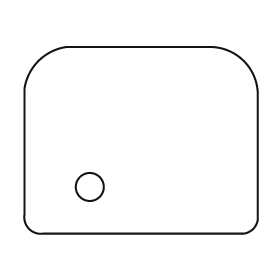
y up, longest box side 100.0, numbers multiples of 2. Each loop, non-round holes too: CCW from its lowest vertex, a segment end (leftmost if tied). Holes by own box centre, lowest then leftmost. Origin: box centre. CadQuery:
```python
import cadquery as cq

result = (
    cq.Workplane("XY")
    .moveTo(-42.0, -40.0)
    .lineTo(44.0, -40.0)
    .threePointArc((48.0, -38.0), (50.0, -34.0))
    .lineTo(50.0, 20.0)
    .threePointArc((44.0, 34.0), (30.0, 40.0))
    .lineTo(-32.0, 40.0)
    .threePointArc((-44.0, 34.0), (-50.0, 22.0))
    .lineTo(-50.0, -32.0)
    .threePointArc((-48.0, -38.0), (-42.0, -40.0))
    .close()
    .moveTo(-22.0, -20.0)
    .circle(6.0)
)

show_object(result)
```